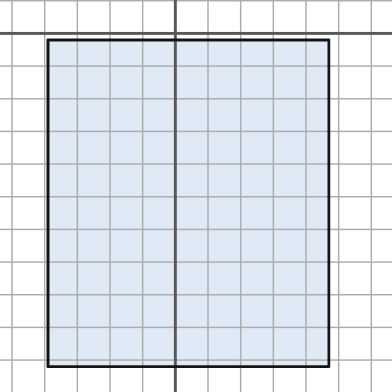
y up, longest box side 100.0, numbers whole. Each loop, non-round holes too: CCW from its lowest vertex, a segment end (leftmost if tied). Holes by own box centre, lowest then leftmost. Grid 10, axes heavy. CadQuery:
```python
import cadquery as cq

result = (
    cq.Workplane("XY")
    .moveTo(-39.0, -102.0)
    .lineTo(47.0, -102.0)
    .lineTo(47.0, -2.0)
    .lineTo(-39.0, -2.0)
    .close()
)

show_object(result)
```